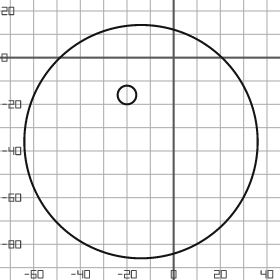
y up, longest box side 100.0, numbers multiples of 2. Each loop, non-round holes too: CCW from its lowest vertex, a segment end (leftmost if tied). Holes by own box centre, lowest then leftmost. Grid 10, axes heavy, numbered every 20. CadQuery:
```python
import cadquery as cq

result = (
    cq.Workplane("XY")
    .moveTo(-14.0, -36.0)
    .circle(50.0)
    .moveTo(-20.0, -16.0)
    .circle(4.0)
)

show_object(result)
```